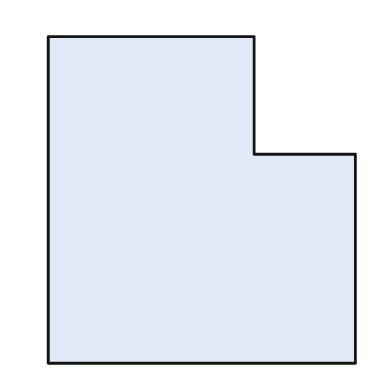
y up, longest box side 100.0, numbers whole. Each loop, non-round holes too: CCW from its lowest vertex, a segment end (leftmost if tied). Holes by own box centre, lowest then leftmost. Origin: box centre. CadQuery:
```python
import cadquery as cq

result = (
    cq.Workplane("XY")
    .moveTo(-47.0, -50.0)
    .lineTo(47.0, -50.0)
    .lineTo(47.0, 14.0)
    .lineTo(16.0, 14.0)
    .lineTo(16.0, 50.0)
    .lineTo(-47.0, 50.0)
    .close()
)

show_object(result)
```